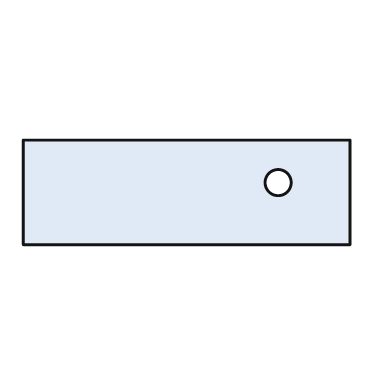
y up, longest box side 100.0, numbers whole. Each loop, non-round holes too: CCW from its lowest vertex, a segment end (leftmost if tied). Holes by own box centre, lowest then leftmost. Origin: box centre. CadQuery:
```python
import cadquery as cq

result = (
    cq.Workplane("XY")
    .moveTo(-50.0, -16.0)
    .lineTo(50.0, -16.0)
    .lineTo(50.0, 16.0)
    .lineTo(-50.0, 16.0)
    .close()
    .moveTo(28.0, 3.0)
    .circle(4.0)
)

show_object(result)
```